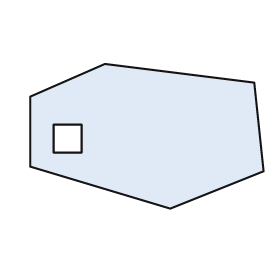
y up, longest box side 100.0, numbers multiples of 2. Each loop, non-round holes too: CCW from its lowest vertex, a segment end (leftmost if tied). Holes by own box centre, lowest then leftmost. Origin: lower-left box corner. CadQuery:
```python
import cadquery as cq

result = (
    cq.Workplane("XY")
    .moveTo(60.0, 0.0)
    .lineTo(100.0, 16.0)
    .lineTo(96.0, 54.0)
    .lineTo(32.0, 62.0)
    .lineTo(0.0, 48.0)
    .lineTo(0.0, 18.0)
    .close()
    .moveTo(10.0, 24.0)
    .lineTo(22.0, 24.0)
    .lineTo(22.0, 36.0)
    .lineTo(10.0, 36.0)
    .close()
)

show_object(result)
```